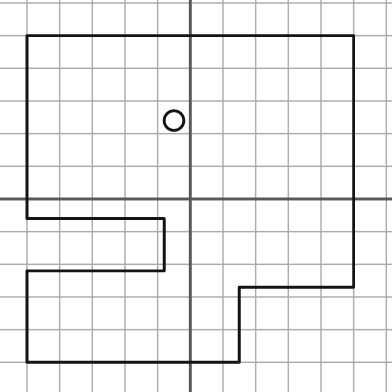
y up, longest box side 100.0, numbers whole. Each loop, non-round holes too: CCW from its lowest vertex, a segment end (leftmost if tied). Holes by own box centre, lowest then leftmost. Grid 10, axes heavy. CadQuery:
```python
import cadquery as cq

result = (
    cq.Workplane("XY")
    .moveTo(-50.0, -50.0)
    .lineTo(15.0, -50.0)
    .lineTo(15.0, -27.0)
    .lineTo(50.0, -27.0)
    .lineTo(50.0, 50.0)
    .lineTo(-50.0, 50.0)
    .lineTo(-50.0, -6.0)
    .lineTo(-8.0, -6.0)
    .lineTo(-8.0, -22.0)
    .lineTo(-50.0, -22.0)
    .close()
    .moveTo(-5.0, 24.0)
    .circle(3.0)
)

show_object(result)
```